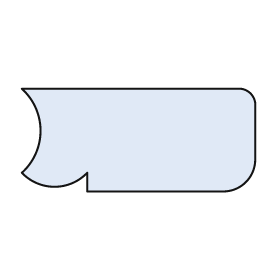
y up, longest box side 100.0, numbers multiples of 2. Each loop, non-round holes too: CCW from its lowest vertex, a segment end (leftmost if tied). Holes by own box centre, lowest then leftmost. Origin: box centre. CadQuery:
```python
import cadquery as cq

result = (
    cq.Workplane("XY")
    .moveTo(-22.0, -22.0)
    .lineTo(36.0, -22.0)
    .threePointArc((46.0, -18.0), (50.0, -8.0))
    .lineTo(50.0, 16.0)
    .threePointArc((48.0, 20.0), (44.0, 22.0))
    .lineTo(-50.0, 22.0)
    .threePointArc((-42.0, 4.0), (-50.0, -14.0))
    .threePointArc((-36.0, -20.0), (-22.0, -14.0))
    .close()
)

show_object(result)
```